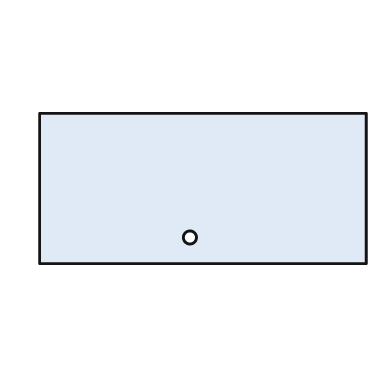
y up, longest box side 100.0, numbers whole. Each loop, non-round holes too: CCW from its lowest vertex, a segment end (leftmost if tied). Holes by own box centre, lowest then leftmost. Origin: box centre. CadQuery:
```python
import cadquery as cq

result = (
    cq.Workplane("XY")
    .moveTo(-50.0, -23.0)
    .lineTo(50.0, -23.0)
    .lineTo(50.0, 23.0)
    .lineTo(-50.0, 23.0)
    .close()
    .moveTo(-4.0, -15.0)
    .circle(2.0)
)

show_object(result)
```